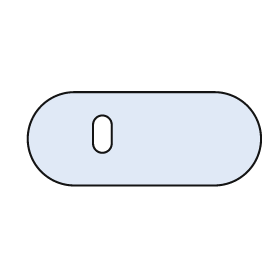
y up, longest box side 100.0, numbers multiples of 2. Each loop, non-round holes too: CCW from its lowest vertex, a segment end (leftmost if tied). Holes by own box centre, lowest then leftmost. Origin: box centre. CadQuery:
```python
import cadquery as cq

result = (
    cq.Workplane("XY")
    .moveTo(-30.0, -20.0)
    .lineTo(30.0, -20.0)
    .threePointArc((50.0, 0.0), (30.0, 20.0))
    .lineTo(-30.0, 20.0)
    .threePointArc((-50.0, 0.0), (-30.0, -20.0))
    .close()
    .moveTo(-22.0, -2.0)
    .threePointArc((-18.0, -6.0), (-14.0, -2.0))
    .lineTo(-14.0, 6.0)
    .threePointArc((-18.0, 10.0), (-22.0, 6.0))
    .close()
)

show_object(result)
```